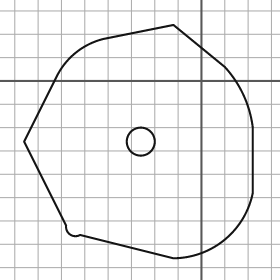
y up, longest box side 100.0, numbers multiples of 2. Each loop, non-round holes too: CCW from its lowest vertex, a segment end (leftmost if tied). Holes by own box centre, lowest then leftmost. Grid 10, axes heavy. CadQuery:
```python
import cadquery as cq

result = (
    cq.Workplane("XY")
    .moveTo(-12.0, -76.0)
    .threePointArc((10.0, -68.0), (22.0, -48.0))
    .lineTo(22.0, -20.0)
    .threePointArc((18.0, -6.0), (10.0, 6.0))
    .lineTo(-12.0, 24.0)
    .lineTo(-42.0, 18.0)
    .threePointArc((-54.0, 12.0), (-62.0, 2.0))
    .lineTo(-76.0, -26.0)
    .lineTo(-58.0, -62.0)
    .threePointArc((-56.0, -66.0), (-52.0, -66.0))
    .close()
    .moveTo(-26.0, -26.0)
    .circle(6.0)
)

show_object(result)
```